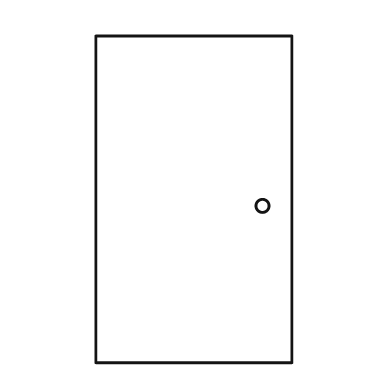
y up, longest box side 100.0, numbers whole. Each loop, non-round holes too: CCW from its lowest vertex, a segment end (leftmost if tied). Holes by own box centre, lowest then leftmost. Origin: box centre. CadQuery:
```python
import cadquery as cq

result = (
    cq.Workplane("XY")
    .moveTo(-30.0, -50.0)
    .lineTo(30.0, -50.0)
    .lineTo(30.0, 50.0)
    .lineTo(-30.0, 50.0)
    .close()
    .moveTo(21.0, -2.0)
    .circle(2.0)
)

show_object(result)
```